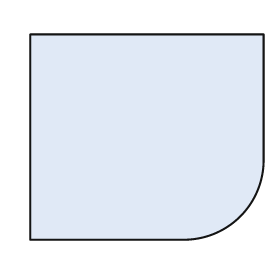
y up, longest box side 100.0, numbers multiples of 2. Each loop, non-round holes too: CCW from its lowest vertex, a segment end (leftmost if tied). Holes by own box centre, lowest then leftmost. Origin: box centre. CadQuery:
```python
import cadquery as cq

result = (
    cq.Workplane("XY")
    .moveTo(-50.0, -44.0)
    .lineTo(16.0, -44.0)
    .threePointArc((40.0, -34.0), (50.0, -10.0))
    .lineTo(50.0, 44.0)
    .lineTo(-50.0, 44.0)
    .close()
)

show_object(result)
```